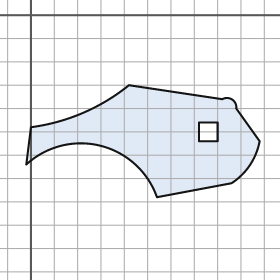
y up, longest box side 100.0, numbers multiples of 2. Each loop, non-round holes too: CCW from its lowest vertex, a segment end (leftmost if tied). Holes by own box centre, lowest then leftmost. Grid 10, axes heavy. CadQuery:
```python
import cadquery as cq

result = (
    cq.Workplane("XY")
    .moveTo(54.0, -78.0)
    .lineTo(86.0, -72.0)
    .threePointArc((94.0, -64.0), (98.0, -54.0))
    .lineTo(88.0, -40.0)
    .threePointArc((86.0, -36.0), (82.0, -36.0))
    .lineTo(42.0, -30.0)
    .threePointArc((22.0, -42.0), (0.0, -48.0))
    .lineTo(-2.0, -64.0)
    .threePointArc((30.0, -56.0), (54.0, -78.0))
    .close()
    .moveTo(72.0, -54.0)
    .lineTo(80.0, -54.0)
    .lineTo(80.0, -46.0)
    .lineTo(72.0, -46.0)
    .close()
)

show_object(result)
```